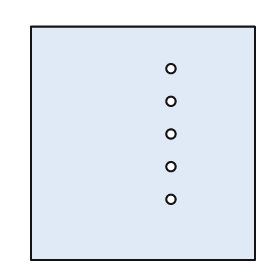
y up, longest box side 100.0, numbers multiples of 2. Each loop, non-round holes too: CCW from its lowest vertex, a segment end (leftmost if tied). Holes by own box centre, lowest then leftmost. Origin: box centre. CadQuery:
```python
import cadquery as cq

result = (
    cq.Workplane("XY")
    .moveTo(-48.0, -50.0)
    .lineTo(48.0, -50.0)
    .lineTo(48.0, 50.0)
    .lineTo(-48.0, 50.0)
    .close()
    .moveTo(12.0, -24.0)
    .circle(2.0)
    .moveTo(12.0, -10.0)
    .circle(2.0)
    .moveTo(12.0, 4.0)
    .circle(2.0)
    .moveTo(12.0, 18.0)
    .circle(2.0)
    .moveTo(12.0, 32.0)
    .circle(2.0)
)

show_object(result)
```